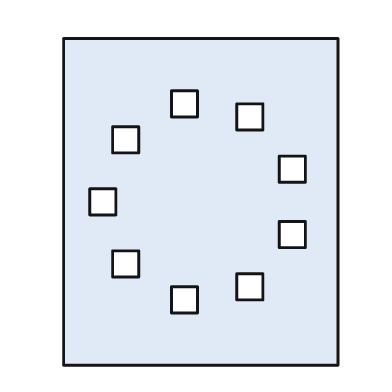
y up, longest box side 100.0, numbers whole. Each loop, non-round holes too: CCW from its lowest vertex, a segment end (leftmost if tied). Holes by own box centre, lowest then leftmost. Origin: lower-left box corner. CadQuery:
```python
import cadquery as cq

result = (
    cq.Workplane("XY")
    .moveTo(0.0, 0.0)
    .lineTo(84.0, 0.0)
    .lineTo(84.0, 100.0)
    .lineTo(0.0, 100.0)
    .close()
    .moveTo(33.0, 16.0)
    .lineTo(41.0, 16.0)
    .lineTo(41.0, 24.0)
    .lineTo(33.0, 24.0)
    .close()
    .moveTo(53.0, 20.0)
    .lineTo(61.0, 20.0)
    .lineTo(61.0, 28.0)
    .lineTo(53.0, 28.0)
    .close()
    .moveTo(15.0, 27.0)
    .lineTo(23.0, 27.0)
    .lineTo(23.0, 35.0)
    .lineTo(15.0, 35.0)
    .close()
    .moveTo(66.0, 36.0)
    .lineTo(74.0, 36.0)
    .lineTo(74.0, 44.0)
    .lineTo(66.0, 44.0)
    .close()
    .moveTo(8.0, 46.0)
    .lineTo(16.0, 46.0)
    .lineTo(16.0, 54.0)
    .lineTo(8.0, 54.0)
    .close()
    .moveTo(66.0, 56.0)
    .lineTo(74.0, 56.0)
    .lineTo(74.0, 64.0)
    .lineTo(66.0, 64.0)
    .close()
    .moveTo(15.0, 65.0)
    .lineTo(23.0, 65.0)
    .lineTo(23.0, 73.0)
    .lineTo(15.0, 73.0)
    .close()
    .moveTo(53.0, 72.0)
    .lineTo(61.0, 72.0)
    .lineTo(61.0, 80.0)
    .lineTo(53.0, 80.0)
    .close()
    .moveTo(33.0, 76.0)
    .lineTo(41.0, 76.0)
    .lineTo(41.0, 84.0)
    .lineTo(33.0, 84.0)
    .close()
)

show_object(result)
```